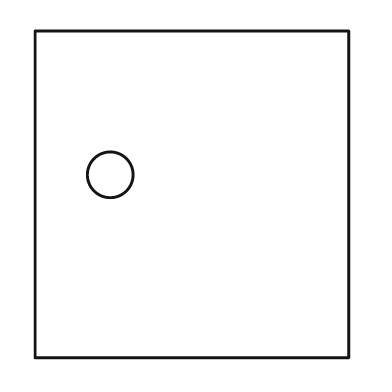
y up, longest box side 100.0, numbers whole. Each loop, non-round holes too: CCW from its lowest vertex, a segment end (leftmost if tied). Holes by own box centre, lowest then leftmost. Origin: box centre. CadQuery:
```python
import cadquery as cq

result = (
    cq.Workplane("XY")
    .moveTo(-48.0, -50.0)
    .lineTo(48.0, -50.0)
    .lineTo(48.0, 50.0)
    .lineTo(-48.0, 50.0)
    .close()
    .moveTo(-25.0, 6.0)
    .circle(7.0)
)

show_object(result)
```